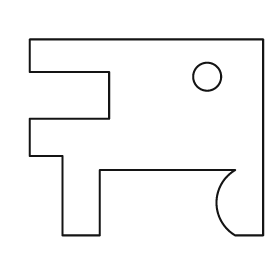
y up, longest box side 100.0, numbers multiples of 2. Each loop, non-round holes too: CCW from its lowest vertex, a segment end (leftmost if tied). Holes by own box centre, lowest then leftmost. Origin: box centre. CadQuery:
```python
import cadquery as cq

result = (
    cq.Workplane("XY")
    .moveTo(-36.0, -42.0)
    .lineTo(-20.0, -42.0)
    .lineTo(-20.0, -14.0)
    .lineTo(38.0, -14.0)
    .threePointArc((30.0, -28.0), (38.0, -42.0))
    .lineTo(50.0, -42.0)
    .lineTo(50.0, 42.0)
    .lineTo(-50.0, 42.0)
    .lineTo(-50.0, 28.0)
    .lineTo(-16.0, 28.0)
    .lineTo(-16.0, 8.0)
    .lineTo(-50.0, 8.0)
    .lineTo(-50.0, -8.0)
    .lineTo(-36.0, -8.0)
    .close()
    .moveTo(26.0, 26.0)
    .circle(6.0)
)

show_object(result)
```